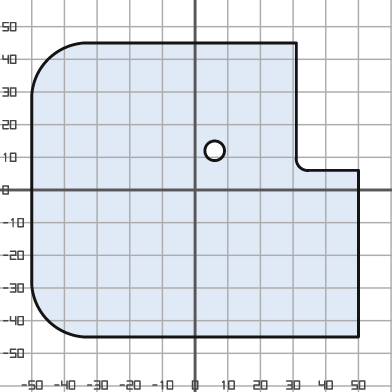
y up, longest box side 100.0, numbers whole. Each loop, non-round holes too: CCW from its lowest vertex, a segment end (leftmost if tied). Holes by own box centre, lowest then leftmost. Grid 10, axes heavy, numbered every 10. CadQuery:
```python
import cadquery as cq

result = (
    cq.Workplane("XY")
    .moveTo(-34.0, -45.0)
    .lineTo(50.0, -45.0)
    .lineTo(50.0, 6.0)
    .lineTo(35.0, 6.0)
    .threePointArc((32.0, 7.0), (31.0, 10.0))
    .lineTo(31.0, 45.0)
    .lineTo(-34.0, 45.0)
    .threePointArc((-45.0, 40.0), (-50.0, 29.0))
    .lineTo(-50.0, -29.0)
    .threePointArc((-45.0, -40.0), (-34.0, -45.0))
    .close()
    .moveTo(6.0, 12.0)
    .circle(3.0)
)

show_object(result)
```